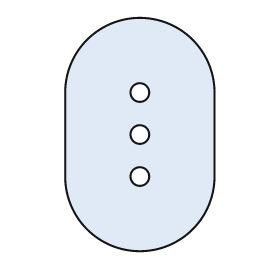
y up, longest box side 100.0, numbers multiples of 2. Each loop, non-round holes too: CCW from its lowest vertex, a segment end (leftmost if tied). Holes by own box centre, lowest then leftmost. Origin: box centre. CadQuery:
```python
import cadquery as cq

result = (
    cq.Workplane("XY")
    .moveTo(-32.0, -18.0)
    .threePointArc((0.0, -50.0), (32.0, -18.0))
    .lineTo(32.0, 18.0)
    .threePointArc((0.0, 50.0), (-32.0, 18.0))
    .close()
    .moveTo(0.0, -18.0)
    .circle(4.0)
    .moveTo(0.0, 0.0)
    .circle(4.0)
    .moveTo(0.0, 18.0)
    .circle(4.0)
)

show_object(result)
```